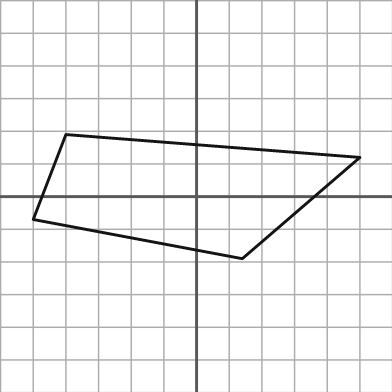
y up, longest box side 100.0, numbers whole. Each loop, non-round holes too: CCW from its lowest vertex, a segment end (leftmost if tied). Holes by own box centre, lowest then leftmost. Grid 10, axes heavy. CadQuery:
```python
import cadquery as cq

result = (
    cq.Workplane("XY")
    .moveTo(14.0, -19.0)
    .lineTo(50.0, 12.0)
    .lineTo(-40.0, 19.0)
    .lineTo(-50.0, -7.0)
    .close()
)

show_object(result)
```